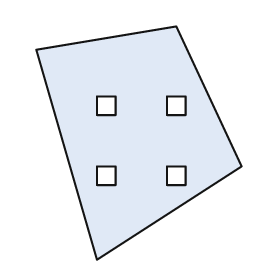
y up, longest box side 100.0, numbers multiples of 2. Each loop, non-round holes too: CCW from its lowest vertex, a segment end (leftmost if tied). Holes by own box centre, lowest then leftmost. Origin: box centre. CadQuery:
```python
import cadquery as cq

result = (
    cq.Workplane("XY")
    .moveTo(-18.0, -50.0)
    .lineTo(44.0, -10.0)
    .lineTo(16.0, 50.0)
    .lineTo(-44.0, 40.0)
    .close()
    .moveTo(-18.0, -18.0)
    .lineTo(-10.0, -18.0)
    .lineTo(-10.0, -10.0)
    .lineTo(-18.0, -10.0)
    .close()
    .moveTo(12.0, -18.0)
    .lineTo(20.0, -18.0)
    .lineTo(20.0, -10.0)
    .lineTo(12.0, -10.0)
    .close()
    .moveTo(-18.0, 12.0)
    .lineTo(-10.0, 12.0)
    .lineTo(-10.0, 20.0)
    .lineTo(-18.0, 20.0)
    .close()
    .moveTo(12.0, 12.0)
    .lineTo(20.0, 12.0)
    .lineTo(20.0, 20.0)
    .lineTo(12.0, 20.0)
    .close()
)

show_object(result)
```